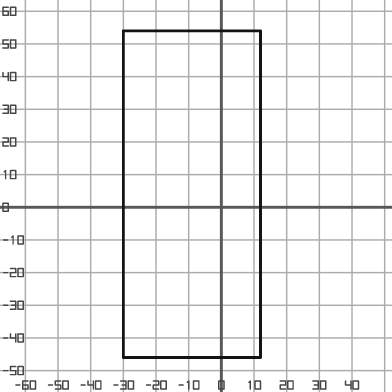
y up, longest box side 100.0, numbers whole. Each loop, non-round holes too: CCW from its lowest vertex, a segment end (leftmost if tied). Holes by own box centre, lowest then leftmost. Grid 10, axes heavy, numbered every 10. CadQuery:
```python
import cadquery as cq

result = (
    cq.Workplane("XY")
    .moveTo(-30.0, -46.0)
    .lineTo(12.0, -46.0)
    .lineTo(12.0, 54.0)
    .lineTo(-30.0, 54.0)
    .close()
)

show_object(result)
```